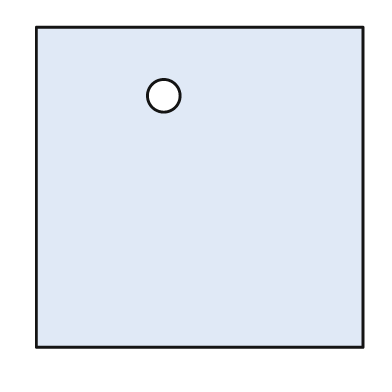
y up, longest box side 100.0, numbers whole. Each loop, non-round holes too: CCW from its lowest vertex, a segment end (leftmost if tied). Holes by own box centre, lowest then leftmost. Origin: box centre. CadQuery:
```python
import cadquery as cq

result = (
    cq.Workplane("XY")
    .moveTo(-50.0, -49.0)
    .lineTo(50.0, -49.0)
    .lineTo(50.0, 49.0)
    .lineTo(-50.0, 49.0)
    .close()
    .moveTo(-11.0, 28.0)
    .circle(5.0)
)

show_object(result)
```